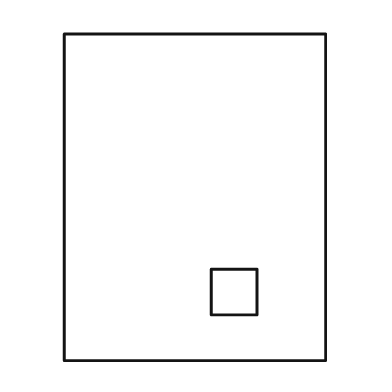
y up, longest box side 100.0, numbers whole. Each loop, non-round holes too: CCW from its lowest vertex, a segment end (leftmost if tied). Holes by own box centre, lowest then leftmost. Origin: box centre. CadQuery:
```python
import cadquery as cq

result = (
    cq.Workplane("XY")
    .moveTo(-40.0, -50.0)
    .lineTo(40.0, -50.0)
    .lineTo(40.0, 50.0)
    .lineTo(-40.0, 50.0)
    .close()
    .moveTo(5.0, -36.0)
    .lineTo(19.0, -36.0)
    .lineTo(19.0, -22.0)
    .lineTo(5.0, -22.0)
    .close()
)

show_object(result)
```